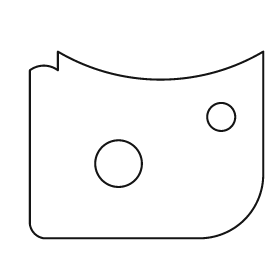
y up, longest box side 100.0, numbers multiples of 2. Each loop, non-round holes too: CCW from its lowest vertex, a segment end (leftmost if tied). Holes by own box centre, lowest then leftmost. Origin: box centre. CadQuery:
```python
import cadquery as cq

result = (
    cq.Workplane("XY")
    .moveTo(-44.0, -40.0)
    .lineTo(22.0, -40.0)
    .threePointArc((42.0, -32.0), (50.0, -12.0))
    .lineTo(50.0, 40.0)
    .threePointArc((6.0, 28.0), (-38.0, 40.0))
    .lineTo(-38.0, 32.0)
    .threePointArc((-44.0, 34.0), (-50.0, 32.0))
    .lineTo(-50.0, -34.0)
    .threePointArc((-48.0, -38.0), (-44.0, -40.0))
    .close()
    .moveTo(-12.0, -8.0)
    .circle(10.0)
    .moveTo(32.0, 12.0)
    .circle(6.0)
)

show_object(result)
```